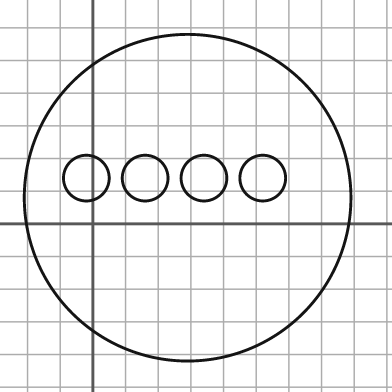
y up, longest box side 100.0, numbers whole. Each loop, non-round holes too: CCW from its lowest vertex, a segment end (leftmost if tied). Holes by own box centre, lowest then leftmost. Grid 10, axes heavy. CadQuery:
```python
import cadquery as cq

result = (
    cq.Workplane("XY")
    .moveTo(29.0, 8.0)
    .circle(50.0)
    .moveTo(-2.0, 14.0)
    .circle(7.0)
    .moveTo(16.0, 14.0)
    .circle(7.0)
    .moveTo(34.0, 14.0)
    .circle(7.0)
    .moveTo(52.0, 14.0)
    .circle(7.0)
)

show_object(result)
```